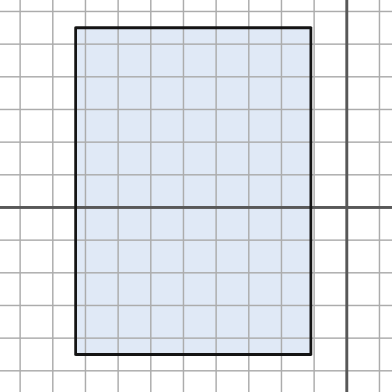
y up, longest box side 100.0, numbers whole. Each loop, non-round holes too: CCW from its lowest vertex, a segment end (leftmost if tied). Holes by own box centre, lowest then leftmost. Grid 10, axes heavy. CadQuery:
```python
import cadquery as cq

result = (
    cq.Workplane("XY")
    .moveTo(-83.0, -45.0)
    .lineTo(-11.0, -45.0)
    .lineTo(-11.0, 55.0)
    .lineTo(-83.0, 55.0)
    .close()
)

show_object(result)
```